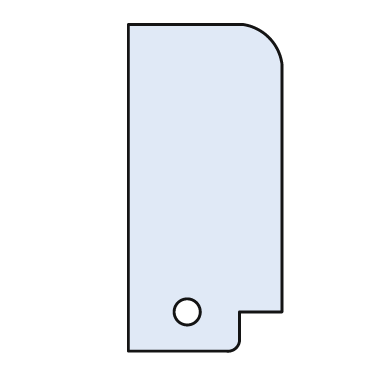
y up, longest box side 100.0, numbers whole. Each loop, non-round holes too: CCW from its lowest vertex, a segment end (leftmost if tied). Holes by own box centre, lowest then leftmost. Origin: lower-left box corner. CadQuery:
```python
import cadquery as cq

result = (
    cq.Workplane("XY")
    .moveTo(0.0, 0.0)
    .lineTo(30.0, 0.0)
    .threePointArc((33.0, 1.0), (34.0, 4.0))
    .lineTo(34.0, 12.0)
    .lineTo(47.0, 12.0)
    .lineTo(47.0, 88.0)
    .threePointArc((43.0, 96.0), (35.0, 100.0))
    .lineTo(0.0, 100.0)
    .close()
    .moveTo(18.0, 12.0)
    .circle(4.0)
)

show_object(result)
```